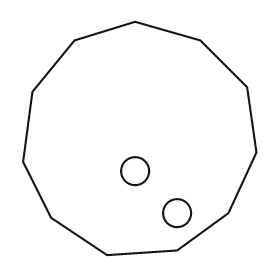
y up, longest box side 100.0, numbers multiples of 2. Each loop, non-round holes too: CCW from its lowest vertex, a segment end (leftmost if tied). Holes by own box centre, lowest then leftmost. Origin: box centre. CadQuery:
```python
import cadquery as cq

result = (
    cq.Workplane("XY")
    .moveTo(-14.0, -50.0)
    .lineTo(16.0, -48.0)
    .lineTo(38.0, -32.0)
    .lineTo(50.0, -6.0)
    .lineTo(46.0, 22.0)
    .lineTo(26.0, 42.0)
    .lineTo(-2.0, 50.0)
    .lineTo(-28.0, 42.0)
    .lineTo(-46.0, 20.0)
    .lineTo(-50.0, -10.0)
    .lineTo(-38.0, -34.0)
    .close()
    .moveTo(16.0, -32.0)
    .circle(6.0)
    .moveTo(-2.0, -14.0)
    .circle(6.0)
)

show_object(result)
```